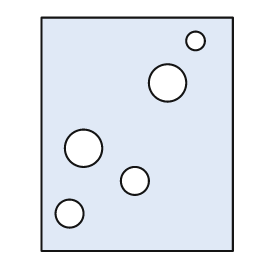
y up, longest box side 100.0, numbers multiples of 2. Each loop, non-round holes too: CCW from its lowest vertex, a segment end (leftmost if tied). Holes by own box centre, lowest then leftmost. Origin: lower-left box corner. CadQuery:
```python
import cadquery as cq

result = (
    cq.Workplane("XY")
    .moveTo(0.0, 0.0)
    .lineTo(82.0, 0.0)
    .lineTo(82.0, 100.0)
    .lineTo(0.0, 100.0)
    .close()
    .moveTo(12.0, 16.0)
    .circle(6.0)
    .moveTo(40.0, 30.0)
    .circle(6.0)
    .moveTo(18.0, 44.0)
    .circle(8.0)
    .moveTo(54.0, 72.0)
    .circle(8.0)
    .moveTo(66.0, 90.0)
    .circle(4.0)
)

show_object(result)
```